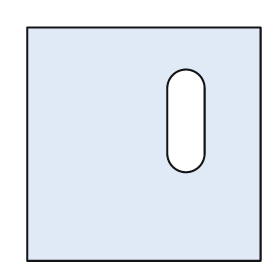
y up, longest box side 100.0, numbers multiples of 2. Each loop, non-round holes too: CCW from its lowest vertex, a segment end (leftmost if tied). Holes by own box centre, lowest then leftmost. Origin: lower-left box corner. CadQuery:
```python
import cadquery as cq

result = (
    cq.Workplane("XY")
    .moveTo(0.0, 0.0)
    .lineTo(100.0, 0.0)
    .lineTo(100.0, 100.0)
    .lineTo(0.0, 100.0)
    .close()
    .moveTo(60.0, 46.0)
    .threePointArc((68.0, 38.0), (76.0, 46.0))
    .lineTo(76.0, 74.0)
    .threePointArc((68.0, 82.0), (60.0, 74.0))
    .close()
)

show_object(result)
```